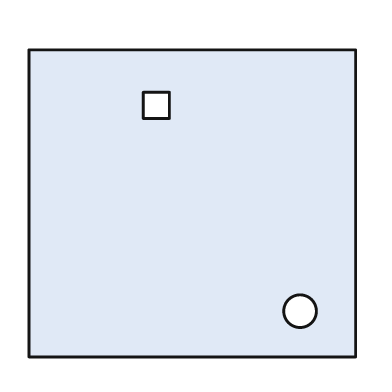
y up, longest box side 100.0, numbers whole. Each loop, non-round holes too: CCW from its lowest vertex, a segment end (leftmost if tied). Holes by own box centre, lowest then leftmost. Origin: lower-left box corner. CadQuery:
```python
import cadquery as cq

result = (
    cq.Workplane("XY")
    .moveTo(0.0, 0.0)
    .lineTo(100.0, 0.0)
    .lineTo(100.0, 94.0)
    .lineTo(0.0, 94.0)
    .close()
    .moveTo(83.0, 14.0)
    .circle(5.0)
    .moveTo(35.0, 73.0)
    .lineTo(43.0, 73.0)
    .lineTo(43.0, 81.0)
    .lineTo(35.0, 81.0)
    .close()
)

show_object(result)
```